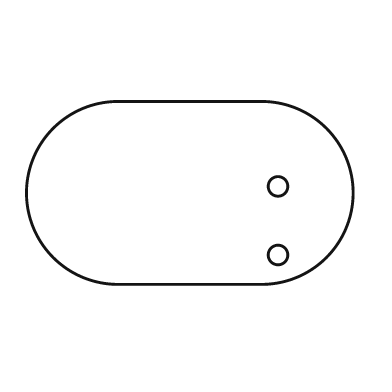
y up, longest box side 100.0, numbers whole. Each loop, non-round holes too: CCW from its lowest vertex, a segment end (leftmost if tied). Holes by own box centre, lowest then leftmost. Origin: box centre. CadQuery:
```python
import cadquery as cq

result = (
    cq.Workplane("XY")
    .moveTo(-22.0, -28.0)
    .lineTo(22.0, -28.0)
    .threePointArc((50.0, 0.0), (22.0, 28.0))
    .lineTo(-22.0, 28.0)
    .threePointArc((-50.0, 0.0), (-22.0, -28.0))
    .close()
    .moveTo(27.0, -19.0)
    .circle(3.0)
    .moveTo(27.0, 2.0)
    .circle(3.0)
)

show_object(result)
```